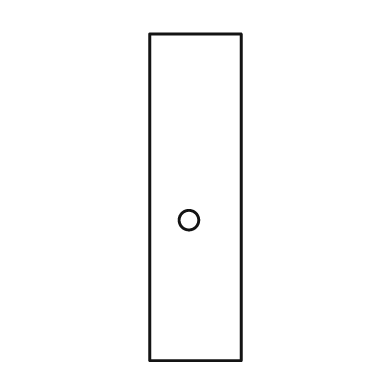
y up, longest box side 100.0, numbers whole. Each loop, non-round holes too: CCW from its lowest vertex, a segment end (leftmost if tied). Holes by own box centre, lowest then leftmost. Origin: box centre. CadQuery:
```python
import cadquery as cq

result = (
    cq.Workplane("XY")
    .moveTo(-14.0, -50.0)
    .lineTo(14.0, -50.0)
    .lineTo(14.0, 50.0)
    .lineTo(-14.0, 50.0)
    .close()
    .moveTo(-2.0, -7.0)
    .circle(3.0)
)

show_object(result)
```